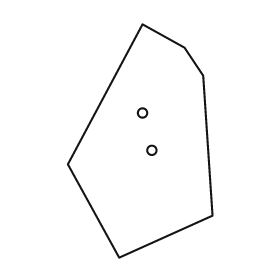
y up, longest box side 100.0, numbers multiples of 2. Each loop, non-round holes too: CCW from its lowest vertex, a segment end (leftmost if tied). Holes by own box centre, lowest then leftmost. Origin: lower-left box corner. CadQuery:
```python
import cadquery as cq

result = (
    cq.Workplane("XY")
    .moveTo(22.0, 0.0)
    .lineTo(62.0, 18.0)
    .lineTo(58.0, 78.0)
    .lineTo(50.0, 90.0)
    .lineTo(32.0, 100.0)
    .lineTo(0.0, 40.0)
    .close()
    .moveTo(36.0, 46.0)
    .circle(2.0)
    .moveTo(32.0, 62.0)
    .circle(2.0)
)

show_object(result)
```